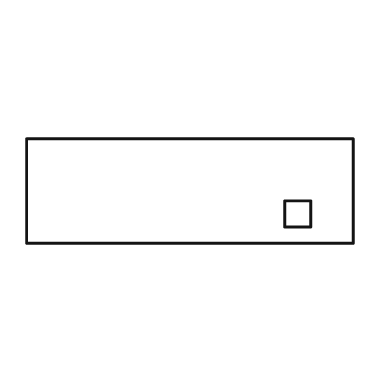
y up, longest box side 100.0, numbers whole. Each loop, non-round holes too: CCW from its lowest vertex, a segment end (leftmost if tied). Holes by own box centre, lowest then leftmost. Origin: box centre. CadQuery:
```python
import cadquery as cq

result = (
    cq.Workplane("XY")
    .moveTo(-50.0, -16.0)
    .lineTo(50.0, -16.0)
    .lineTo(50.0, 16.0)
    .lineTo(-50.0, 16.0)
    .close()
    .moveTo(29.0, -11.0)
    .lineTo(37.0, -11.0)
    .lineTo(37.0, -3.0)
    .lineTo(29.0, -3.0)
    .close()
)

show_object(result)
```